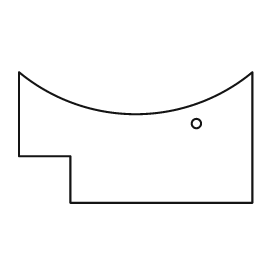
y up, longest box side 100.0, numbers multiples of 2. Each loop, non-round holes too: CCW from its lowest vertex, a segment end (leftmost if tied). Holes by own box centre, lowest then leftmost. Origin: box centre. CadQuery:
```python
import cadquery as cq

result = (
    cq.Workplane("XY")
    .moveTo(-28.0, -28.0)
    .lineTo(50.0, -28.0)
    .lineTo(50.0, 28.0)
    .threePointArc((0.0, 10.0), (-50.0, 28.0))
    .lineTo(-50.0, -8.0)
    .lineTo(-28.0, -8.0)
    .close()
    .moveTo(26.0, 6.0)
    .circle(2.0)
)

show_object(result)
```